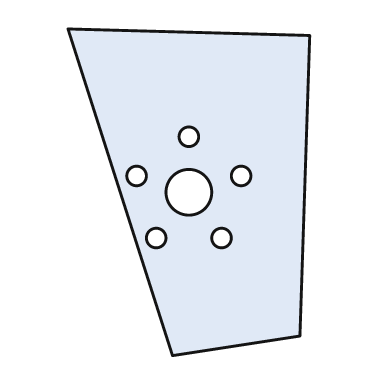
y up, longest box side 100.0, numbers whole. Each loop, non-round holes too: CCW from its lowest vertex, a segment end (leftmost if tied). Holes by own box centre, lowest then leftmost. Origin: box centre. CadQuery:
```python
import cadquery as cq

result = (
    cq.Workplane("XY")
    .moveTo(-5.0, -50.0)
    .lineTo(34.0, -44.0)
    .lineTo(37.0, 48.0)
    .lineTo(-37.0, 50.0)
    .close()
    .moveTo(-10.0, -14.0)
    .circle(3.0)
    .moveTo(10.0, -14.0)
    .circle(3.0)
    .moveTo(0.0, 0.0)
    .circle(7.0)
    .moveTo(-16.0, 5.0)
    .circle(3.0)
    .moveTo(16.0, 5.0)
    .circle(3.0)
    .moveTo(0.0, 17.0)
    .circle(3.0)
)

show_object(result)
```